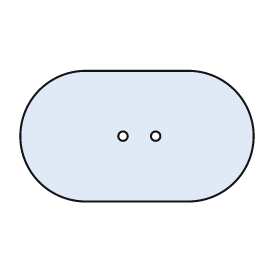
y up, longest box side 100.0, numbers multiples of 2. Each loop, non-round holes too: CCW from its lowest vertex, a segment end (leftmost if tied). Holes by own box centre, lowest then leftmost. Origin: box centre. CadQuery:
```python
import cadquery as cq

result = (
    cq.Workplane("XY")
    .moveTo(-22.0, -28.0)
    .lineTo(22.0, -28.0)
    .threePointArc((50.0, 0.0), (22.0, 28.0))
    .lineTo(-22.0, 28.0)
    .threePointArc((-50.0, 0.0), (-22.0, -28.0))
    .close()
    .moveTo(-6.0, 0.0)
    .circle(2.0)
    .moveTo(8.0, 0.0)
    .circle(2.0)
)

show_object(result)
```